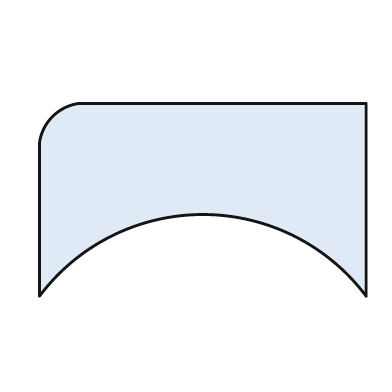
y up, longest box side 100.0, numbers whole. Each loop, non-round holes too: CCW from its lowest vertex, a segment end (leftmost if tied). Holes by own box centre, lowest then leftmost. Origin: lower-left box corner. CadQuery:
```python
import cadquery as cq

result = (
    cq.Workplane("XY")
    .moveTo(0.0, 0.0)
    .threePointArc((50.0, 25.0), (100.0, 0.0))
    .lineTo(100.0, 59.0)
    .lineTo(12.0, 59.0)
    .threePointArc((4.0, 55.0), (0.0, 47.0))
    .close()
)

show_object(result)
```